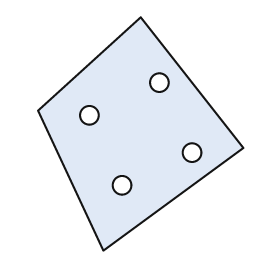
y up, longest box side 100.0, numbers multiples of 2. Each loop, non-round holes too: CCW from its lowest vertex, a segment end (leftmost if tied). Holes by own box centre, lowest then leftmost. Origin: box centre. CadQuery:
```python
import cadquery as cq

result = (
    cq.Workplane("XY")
    .moveTo(-16.0, -50.0)
    .lineTo(44.0, -6.0)
    .lineTo(0.0, 50.0)
    .lineTo(-44.0, 10.0)
    .close()
    .moveTo(-8.0, -22.0)
    .circle(4.0)
    .moveTo(22.0, -8.0)
    .circle(4.0)
    .moveTo(-22.0, 8.0)
    .circle(4.0)
    .moveTo(8.0, 22.0)
    .circle(4.0)
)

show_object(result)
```